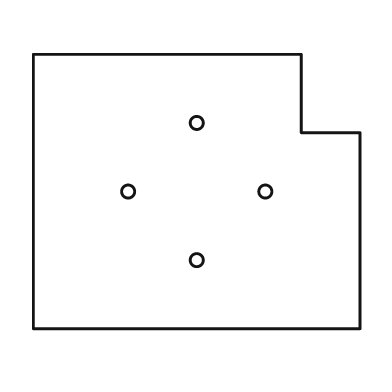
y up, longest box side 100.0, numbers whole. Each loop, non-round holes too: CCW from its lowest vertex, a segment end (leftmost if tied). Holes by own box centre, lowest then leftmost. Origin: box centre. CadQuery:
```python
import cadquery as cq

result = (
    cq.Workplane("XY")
    .moveTo(-50.0, -42.0)
    .lineTo(50.0, -42.0)
    .lineTo(50.0, 18.0)
    .lineTo(32.0, 18.0)
    .lineTo(32.0, 42.0)
    .lineTo(-50.0, 42.0)
    .close()
    .moveTo(0.0, -21.0)
    .circle(2.0)
    .moveTo(-21.0, 0.0)
    .circle(2.0)
    .moveTo(21.0, 0.0)
    .circle(2.0)
    .moveTo(0.0, 21.0)
    .circle(2.0)
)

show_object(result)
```